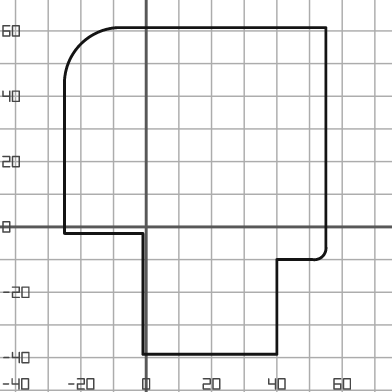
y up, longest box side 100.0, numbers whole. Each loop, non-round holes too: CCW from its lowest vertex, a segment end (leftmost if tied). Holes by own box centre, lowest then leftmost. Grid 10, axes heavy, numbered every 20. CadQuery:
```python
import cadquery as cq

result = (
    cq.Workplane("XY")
    .moveTo(-1.0, -39.0)
    .lineTo(40.0, -39.0)
    .lineTo(40.0, -10.0)
    .lineTo(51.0, -10.0)
    .threePointArc((54.0, -9.0), (55.0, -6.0))
    .lineTo(55.0, 61.0)
    .lineTo(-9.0, 61.0)
    .threePointArc((-20.0, 56.0), (-25.0, 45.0))
    .lineTo(-25.0, -2.0)
    .lineTo(-1.0, -2.0)
    .close()
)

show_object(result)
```